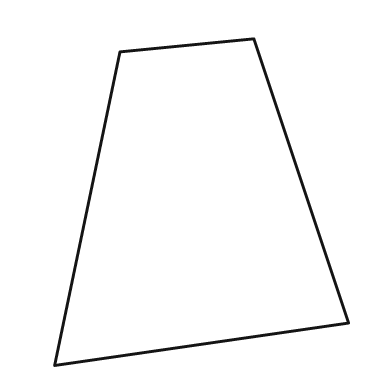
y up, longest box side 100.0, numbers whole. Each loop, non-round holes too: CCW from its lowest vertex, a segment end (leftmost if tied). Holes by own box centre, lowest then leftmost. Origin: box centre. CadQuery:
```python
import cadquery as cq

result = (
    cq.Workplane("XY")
    .moveTo(-45.0, -50.0)
    .lineTo(45.0, -37.0)
    .lineTo(16.0, 50.0)
    .lineTo(-25.0, 46.0)
    .close()
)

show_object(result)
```